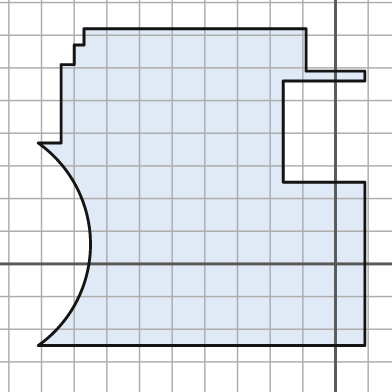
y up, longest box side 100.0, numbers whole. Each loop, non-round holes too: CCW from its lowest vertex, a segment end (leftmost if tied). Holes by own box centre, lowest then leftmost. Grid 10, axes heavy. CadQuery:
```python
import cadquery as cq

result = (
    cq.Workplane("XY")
    .moveTo(-91.0, -25.0)
    .lineTo(9.0, -25.0)
    .lineTo(9.0, 25.0)
    .lineTo(-16.0, 25.0)
    .lineTo(-16.0, 56.0)
    .lineTo(9.0, 56.0)
    .lineTo(9.0, 59.0)
    .lineTo(-9.0, 59.0)
    .lineTo(-9.0, 72.0)
    .lineTo(-77.0, 72.0)
    .lineTo(-77.0, 67.0)
    .lineTo(-80.0, 67.0)
    .lineTo(-80.0, 61.0)
    .lineTo(-84.0, 61.0)
    .lineTo(-84.0, 37.0)
    .lineTo(-91.0, 37.0)
    .threePointArc((-75.0, 6.0), (-91.0, -25.0))
    .close()
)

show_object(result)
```